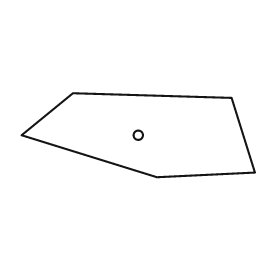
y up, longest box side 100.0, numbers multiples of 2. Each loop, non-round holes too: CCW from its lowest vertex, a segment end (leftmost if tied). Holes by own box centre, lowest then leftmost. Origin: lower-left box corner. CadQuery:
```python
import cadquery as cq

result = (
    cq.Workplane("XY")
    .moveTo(58.0, 0.0)
    .lineTo(100.0, 2.0)
    .lineTo(90.0, 34.0)
    .lineTo(22.0, 36.0)
    .lineTo(0.0, 18.0)
    .close()
    .moveTo(50.0, 18.0)
    .circle(2.0)
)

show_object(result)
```